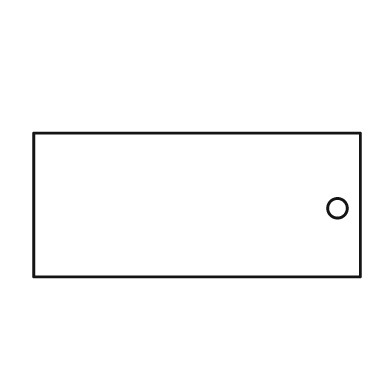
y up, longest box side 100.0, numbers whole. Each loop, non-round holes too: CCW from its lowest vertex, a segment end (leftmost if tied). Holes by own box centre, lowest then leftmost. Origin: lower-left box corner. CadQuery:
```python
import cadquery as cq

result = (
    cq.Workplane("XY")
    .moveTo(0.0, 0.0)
    .lineTo(100.0, 0.0)
    .lineTo(100.0, 44.0)
    .lineTo(0.0, 44.0)
    .close()
    .moveTo(93.0, 21.0)
    .circle(3.0)
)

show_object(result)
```